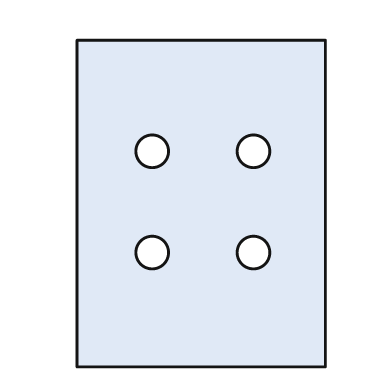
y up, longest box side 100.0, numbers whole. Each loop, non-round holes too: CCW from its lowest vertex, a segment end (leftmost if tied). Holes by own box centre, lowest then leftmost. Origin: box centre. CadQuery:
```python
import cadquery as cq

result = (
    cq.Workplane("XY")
    .moveTo(-38.0, -50.0)
    .lineTo(38.0, -50.0)
    .lineTo(38.0, 50.0)
    .lineTo(-38.0, 50.0)
    .close()
    .moveTo(-15.0, -15.0)
    .circle(5.0)
    .moveTo(16.0, -15.0)
    .circle(5.0)
    .moveTo(-15.0, 16.0)
    .circle(5.0)
    .moveTo(16.0, 16.0)
    .circle(5.0)
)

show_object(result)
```